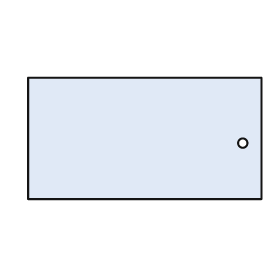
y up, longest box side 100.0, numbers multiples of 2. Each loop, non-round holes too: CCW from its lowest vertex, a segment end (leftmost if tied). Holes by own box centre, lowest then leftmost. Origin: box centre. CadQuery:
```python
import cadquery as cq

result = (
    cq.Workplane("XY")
    .moveTo(-50.0, -26.0)
    .lineTo(50.0, -26.0)
    .lineTo(50.0, 26.0)
    .lineTo(-50.0, 26.0)
    .close()
    .moveTo(42.0, -2.0)
    .circle(2.0)
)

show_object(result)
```